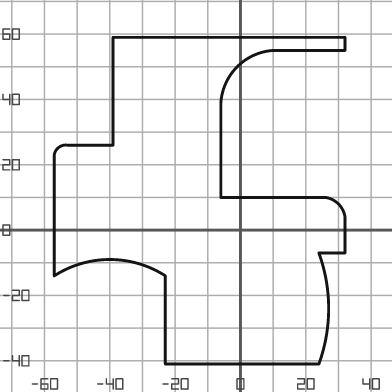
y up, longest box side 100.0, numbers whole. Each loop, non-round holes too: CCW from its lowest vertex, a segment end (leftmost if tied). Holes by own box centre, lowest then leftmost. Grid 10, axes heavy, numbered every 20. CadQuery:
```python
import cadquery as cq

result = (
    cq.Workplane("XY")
    .moveTo(-23.0, -41.0)
    .lineTo(24.0, -41.0)
    .threePointArc((27.0, -24.0), (24.0, -7.0))
    .lineTo(32.0, -7.0)
    .lineTo(32.0, 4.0)
    .threePointArc((30.0, 8.0), (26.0, 10.0))
    .lineTo(-6.0, 10.0)
    .lineTo(-6.0, 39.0)
    .threePointArc((-1.0, 50.0), (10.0, 55.0))
    .lineTo(32.0, 55.0)
    .lineTo(32.0, 59.0)
    .lineTo(-39.0, 59.0)
    .lineTo(-39.0, 26.0)
    .lineTo(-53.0, 26.0)
    .threePointArc((-56.0, 25.0), (-57.0, 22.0))
    .lineTo(-57.0, -14.0)
    .threePointArc((-40.0, -9.0), (-23.0, -14.0))
    .close()
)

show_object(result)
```